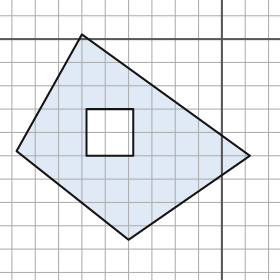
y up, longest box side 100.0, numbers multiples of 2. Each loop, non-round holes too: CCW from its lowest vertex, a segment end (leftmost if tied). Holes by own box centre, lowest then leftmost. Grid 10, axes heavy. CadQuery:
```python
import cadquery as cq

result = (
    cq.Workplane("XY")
    .moveTo(-40.0, -86.0)
    .lineTo(12.0, -50.0)
    .lineTo(-60.0, 2.0)
    .lineTo(-88.0, -48.0)
    .close()
    .moveTo(-58.0, -50.0)
    .lineTo(-38.0, -50.0)
    .lineTo(-38.0, -30.0)
    .lineTo(-58.0, -30.0)
    .close()
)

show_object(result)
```